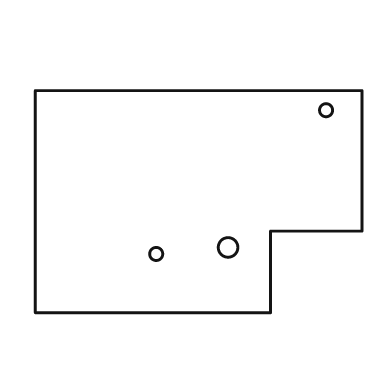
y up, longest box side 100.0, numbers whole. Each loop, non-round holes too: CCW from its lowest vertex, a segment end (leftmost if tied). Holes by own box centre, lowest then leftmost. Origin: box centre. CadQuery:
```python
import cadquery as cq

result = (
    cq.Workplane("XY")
    .moveTo(-50.0, -34.0)
    .lineTo(22.0, -34.0)
    .lineTo(22.0, -9.0)
    .lineTo(50.0, -9.0)
    .lineTo(50.0, 34.0)
    .lineTo(-50.0, 34.0)
    .close()
    .moveTo(-13.0, -16.0)
    .circle(2.0)
    .moveTo(9.0, -14.0)
    .circle(3.0)
    .moveTo(39.0, 28.0)
    .circle(2.0)
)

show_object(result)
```